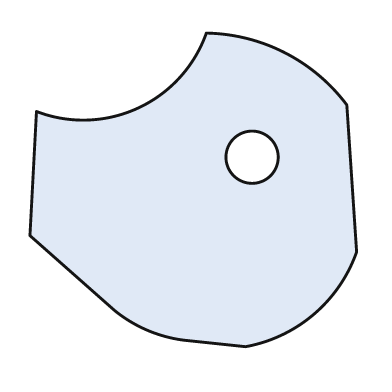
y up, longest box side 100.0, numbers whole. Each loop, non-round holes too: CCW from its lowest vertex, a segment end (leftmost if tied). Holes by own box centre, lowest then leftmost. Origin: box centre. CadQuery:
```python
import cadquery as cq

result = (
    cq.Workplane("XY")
    .moveTo(16.0, -48.0)
    .threePointArc((37.0, -38.0), (50.0, -19.0))
    .lineTo(47.0, 26.0)
    .threePointArc((28.0, 42.0), (4.0, 48.0))
    .threePointArc((-17.0, 25.0), (-48.0, 24.0))
    .lineTo(-50.0, -14.0)
    .lineTo(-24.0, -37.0)
    .threePointArc((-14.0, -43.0), (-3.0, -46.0))
    .close()
    .moveTo(18.0, 10.0)
    .circle(8.0)
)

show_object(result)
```